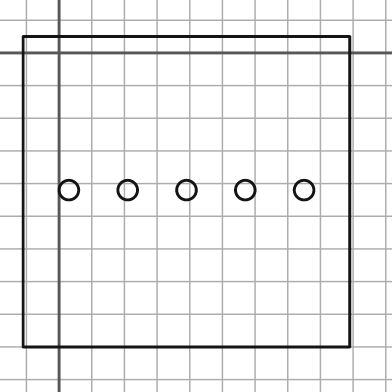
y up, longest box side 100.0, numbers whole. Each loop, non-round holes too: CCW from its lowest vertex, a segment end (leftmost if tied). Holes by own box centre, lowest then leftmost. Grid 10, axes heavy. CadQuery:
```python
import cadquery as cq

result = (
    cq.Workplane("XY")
    .moveTo(-11.0, -90.0)
    .lineTo(89.0, -90.0)
    .lineTo(89.0, 5.0)
    .lineTo(-11.0, 5.0)
    .close()
    .moveTo(3.0, -42.0)
    .circle(3.0)
    .moveTo(21.0, -42.0)
    .circle(3.0)
    .moveTo(39.0, -42.0)
    .circle(3.0)
    .moveTo(57.0, -42.0)
    .circle(3.0)
    .moveTo(75.0, -42.0)
    .circle(3.0)
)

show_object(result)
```